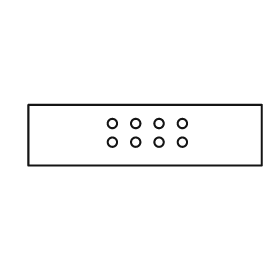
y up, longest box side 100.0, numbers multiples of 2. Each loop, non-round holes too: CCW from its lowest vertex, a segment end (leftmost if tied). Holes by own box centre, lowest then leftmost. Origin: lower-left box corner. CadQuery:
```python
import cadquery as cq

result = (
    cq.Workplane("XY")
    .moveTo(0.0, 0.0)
    .lineTo(100.0, 0.0)
    .lineTo(100.0, 26.0)
    .lineTo(0.0, 26.0)
    .close()
    .moveTo(36.0, 10.0)
    .circle(2.0)
    .moveTo(46.0, 10.0)
    .circle(2.0)
    .moveTo(56.0, 10.0)
    .circle(2.0)
    .moveTo(66.0, 10.0)
    .circle(2.0)
    .moveTo(36.0, 18.0)
    .circle(2.0)
    .moveTo(46.0, 18.0)
    .circle(2.0)
    .moveTo(56.0, 18.0)
    .circle(2.0)
    .moveTo(66.0, 18.0)
    .circle(2.0)
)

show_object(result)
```